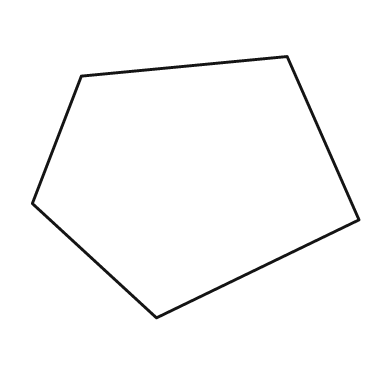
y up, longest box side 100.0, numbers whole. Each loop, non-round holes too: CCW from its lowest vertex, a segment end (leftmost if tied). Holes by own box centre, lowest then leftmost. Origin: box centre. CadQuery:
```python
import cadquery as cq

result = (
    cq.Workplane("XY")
    .moveTo(-12.0, -40.0)
    .lineTo(50.0, -10.0)
    .lineTo(28.0, 40.0)
    .lineTo(-35.0, 34.0)
    .lineTo(-50.0, -5.0)
    .close()
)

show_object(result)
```